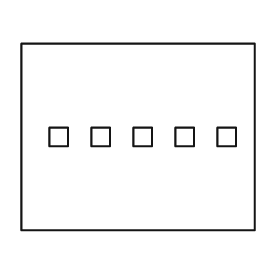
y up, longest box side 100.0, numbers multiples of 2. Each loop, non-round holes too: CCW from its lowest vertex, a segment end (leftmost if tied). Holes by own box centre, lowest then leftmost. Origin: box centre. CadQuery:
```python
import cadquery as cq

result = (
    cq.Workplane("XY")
    .moveTo(-50.0, -40.0)
    .lineTo(50.0, -40.0)
    .lineTo(50.0, 40.0)
    .lineTo(-50.0, 40.0)
    .close()
    .moveTo(-38.0, -4.0)
    .lineTo(-30.0, -4.0)
    .lineTo(-30.0, 4.0)
    .lineTo(-38.0, 4.0)
    .close()
    .moveTo(-20.0, -4.0)
    .lineTo(-12.0, -4.0)
    .lineTo(-12.0, 4.0)
    .lineTo(-20.0, 4.0)
    .close()
    .moveTo(-2.0, -4.0)
    .lineTo(6.0, -4.0)
    .lineTo(6.0, 4.0)
    .lineTo(-2.0, 4.0)
    .close()
    .moveTo(16.0, -4.0)
    .lineTo(24.0, -4.0)
    .lineTo(24.0, 4.0)
    .lineTo(16.0, 4.0)
    .close()
    .moveTo(34.0, -4.0)
    .lineTo(42.0, -4.0)
    .lineTo(42.0, 4.0)
    .lineTo(34.0, 4.0)
    .close()
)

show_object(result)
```